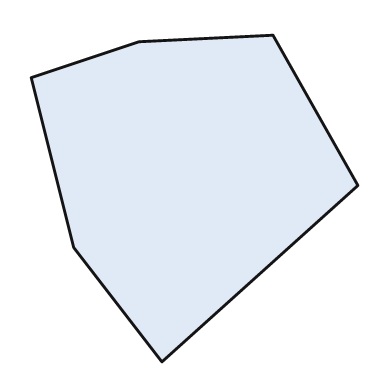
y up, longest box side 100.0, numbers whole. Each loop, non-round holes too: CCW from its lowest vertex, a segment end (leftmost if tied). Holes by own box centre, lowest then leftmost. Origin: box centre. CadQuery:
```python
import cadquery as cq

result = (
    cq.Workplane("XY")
    .moveTo(-10.0, -50.0)
    .lineTo(50.0, 4.0)
    .lineTo(24.0, 50.0)
    .lineTo(-17.0, 48.0)
    .lineTo(-50.0, 37.0)
    .lineTo(-37.0, -15.0)
    .close()
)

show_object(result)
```